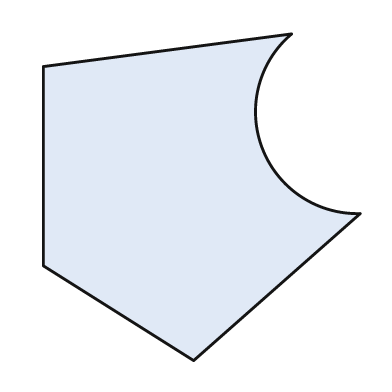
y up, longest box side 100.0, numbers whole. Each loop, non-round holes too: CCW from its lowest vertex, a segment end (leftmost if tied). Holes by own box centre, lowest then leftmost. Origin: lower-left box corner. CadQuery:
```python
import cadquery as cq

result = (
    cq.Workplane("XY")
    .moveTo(46.0, 0.0)
    .lineTo(97.0, 45.0)
    .threePointArc((67.0, 65.0), (76.0, 100.0))
    .lineTo(0.0, 90.0)
    .lineTo(0.0, 29.0)
    .close()
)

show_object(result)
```